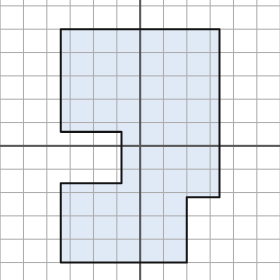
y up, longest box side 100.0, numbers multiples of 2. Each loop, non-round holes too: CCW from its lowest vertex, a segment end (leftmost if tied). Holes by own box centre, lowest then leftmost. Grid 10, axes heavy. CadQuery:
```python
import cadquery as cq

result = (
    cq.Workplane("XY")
    .moveTo(-34.0, -50.0)
    .lineTo(20.0, -50.0)
    .lineTo(20.0, -22.0)
    .lineTo(34.0, -22.0)
    .lineTo(34.0, 50.0)
    .lineTo(-34.0, 50.0)
    .lineTo(-34.0, 6.0)
    .lineTo(-8.0, 6.0)
    .lineTo(-8.0, -16.0)
    .lineTo(-34.0, -16.0)
    .close()
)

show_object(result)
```